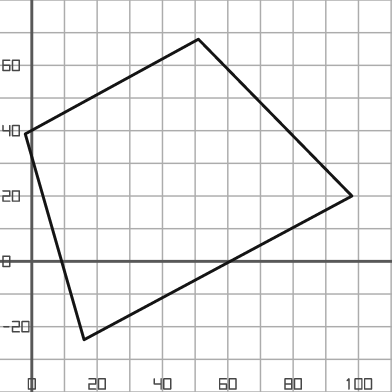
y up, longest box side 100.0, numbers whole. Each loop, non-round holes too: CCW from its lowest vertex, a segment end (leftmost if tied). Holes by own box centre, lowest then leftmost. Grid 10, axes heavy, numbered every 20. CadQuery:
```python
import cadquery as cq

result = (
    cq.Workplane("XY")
    .moveTo(16.0, -24.0)
    .lineTo(98.0, 20.0)
    .lineTo(51.0, 68.0)
    .lineTo(-2.0, 39.0)
    .close()
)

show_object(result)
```